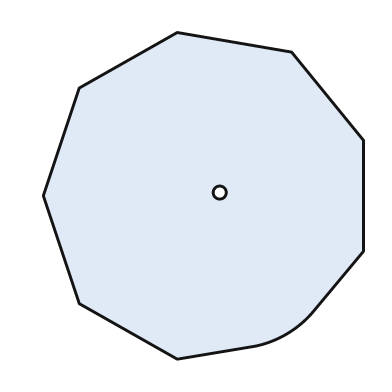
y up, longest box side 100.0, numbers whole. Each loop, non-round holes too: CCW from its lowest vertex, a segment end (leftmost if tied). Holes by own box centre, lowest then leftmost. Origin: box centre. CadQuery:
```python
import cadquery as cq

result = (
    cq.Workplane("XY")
    .moveTo(-8.0, -50.0)
    .lineTo(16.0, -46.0)
    .threePointArc((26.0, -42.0), (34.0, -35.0))
    .lineTo(49.0, -17.0)
    .lineTo(49.0, 17.0)
    .lineTo(27.0, 44.0)
    .lineTo(-8.0, 50.0)
    .lineTo(-38.0, 33.0)
    .lineTo(-49.0, 0.0)
    .lineTo(-38.0, -33.0)
    .close()
    .moveTo(5.0, 1.0)
    .circle(2.0)
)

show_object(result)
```